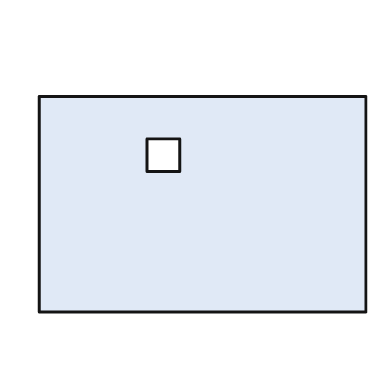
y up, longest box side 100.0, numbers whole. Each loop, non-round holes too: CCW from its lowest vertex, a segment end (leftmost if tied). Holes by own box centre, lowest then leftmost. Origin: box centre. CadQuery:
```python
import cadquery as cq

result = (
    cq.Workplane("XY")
    .moveTo(-50.0, -33.0)
    .lineTo(50.0, -33.0)
    .lineTo(50.0, 33.0)
    .lineTo(-50.0, 33.0)
    .close()
    .moveTo(-17.0, 10.0)
    .lineTo(-7.0, 10.0)
    .lineTo(-7.0, 20.0)
    .lineTo(-17.0, 20.0)
    .close()
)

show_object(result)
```